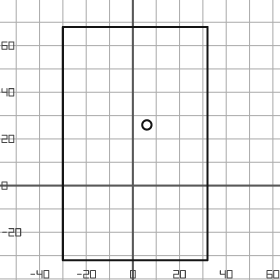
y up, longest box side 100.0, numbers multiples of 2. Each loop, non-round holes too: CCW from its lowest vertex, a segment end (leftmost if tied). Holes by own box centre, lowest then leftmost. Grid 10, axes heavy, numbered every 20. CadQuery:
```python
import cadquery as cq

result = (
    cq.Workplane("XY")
    .moveTo(-30.0, -32.0)
    .lineTo(32.0, -32.0)
    .lineTo(32.0, 68.0)
    .lineTo(-30.0, 68.0)
    .close()
    .moveTo(6.0, 26.0)
    .circle(2.0)
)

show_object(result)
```